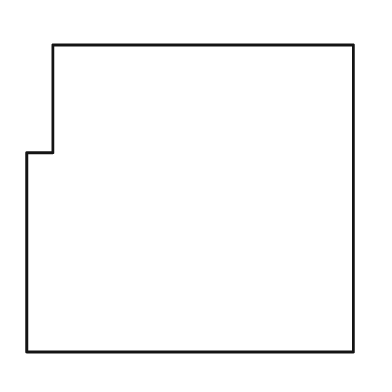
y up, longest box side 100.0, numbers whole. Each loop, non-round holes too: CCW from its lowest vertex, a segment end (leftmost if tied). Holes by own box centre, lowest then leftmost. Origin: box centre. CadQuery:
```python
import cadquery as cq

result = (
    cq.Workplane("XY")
    .moveTo(-50.0, -47.0)
    .lineTo(50.0, -47.0)
    .lineTo(50.0, 47.0)
    .lineTo(-42.0, 47.0)
    .lineTo(-42.0, 14.0)
    .lineTo(-50.0, 14.0)
    .close()
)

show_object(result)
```